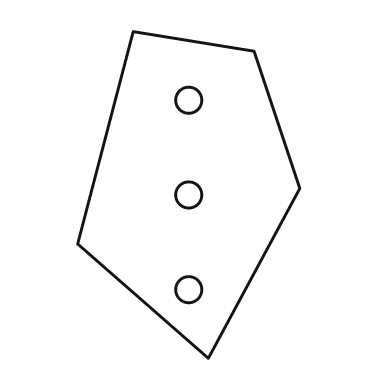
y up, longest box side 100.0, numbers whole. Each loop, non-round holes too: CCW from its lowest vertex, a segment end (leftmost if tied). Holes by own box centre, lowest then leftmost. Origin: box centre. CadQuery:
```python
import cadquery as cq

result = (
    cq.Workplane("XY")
    .moveTo(6.0, -50.0)
    .lineTo(34.0, 2.0)
    .lineTo(20.0, 44.0)
    .lineTo(-17.0, 50.0)
    .lineTo(-34.0, -15.0)
    .close()
    .moveTo(0.0, -29.0)
    .circle(4.0)
    .moveTo(0.0, 0.0)
    .circle(4.0)
    .moveTo(0.0, 29.0)
    .circle(4.0)
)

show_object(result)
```